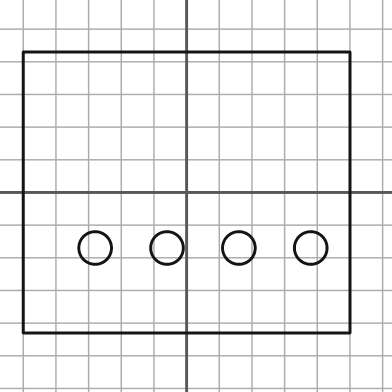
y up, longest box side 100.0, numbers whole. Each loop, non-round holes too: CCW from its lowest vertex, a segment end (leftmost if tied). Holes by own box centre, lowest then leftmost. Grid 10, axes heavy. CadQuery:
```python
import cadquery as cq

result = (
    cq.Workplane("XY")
    .moveTo(-50.0, -43.0)
    .lineTo(50.0, -43.0)
    .lineTo(50.0, 43.0)
    .lineTo(-50.0, 43.0)
    .close()
    .moveTo(-28.0, -17.0)
    .circle(5.0)
    .moveTo(-6.0, -17.0)
    .circle(5.0)
    .moveTo(16.0, -17.0)
    .circle(5.0)
    .moveTo(38.0, -17.0)
    .circle(5.0)
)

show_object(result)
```